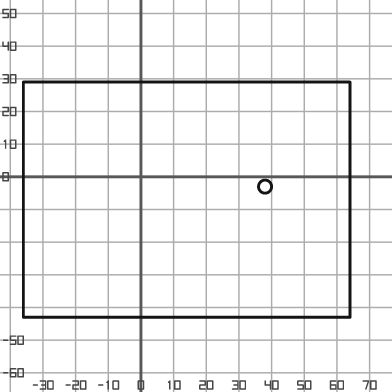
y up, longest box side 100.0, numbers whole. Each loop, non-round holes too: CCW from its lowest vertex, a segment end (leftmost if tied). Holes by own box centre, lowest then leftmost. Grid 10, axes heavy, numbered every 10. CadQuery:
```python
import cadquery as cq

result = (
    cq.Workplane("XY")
    .moveTo(-36.0, -43.0)
    .lineTo(64.0, -43.0)
    .lineTo(64.0, 29.0)
    .lineTo(-36.0, 29.0)
    .close()
    .moveTo(38.0, -3.0)
    .circle(2.0)
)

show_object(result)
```